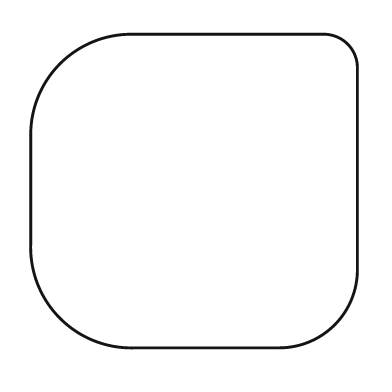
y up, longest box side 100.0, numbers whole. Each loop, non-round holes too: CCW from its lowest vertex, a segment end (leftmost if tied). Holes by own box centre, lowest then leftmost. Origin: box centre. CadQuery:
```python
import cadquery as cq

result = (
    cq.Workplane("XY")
    .moveTo(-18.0, -48.0)
    .lineTo(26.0, -48.0)
    .threePointArc((43.0, -41.0), (50.0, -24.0))
    .lineTo(50.0, 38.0)
    .threePointArc((47.0, 45.0), (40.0, 48.0))
    .lineTo(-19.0, 48.0)
    .threePointArc((-41.0, 39.0), (-50.0, 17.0))
    .lineTo(-50.0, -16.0)
    .threePointArc((-41.0, -39.0), (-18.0, -48.0))
    .close()
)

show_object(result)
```